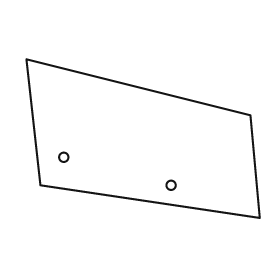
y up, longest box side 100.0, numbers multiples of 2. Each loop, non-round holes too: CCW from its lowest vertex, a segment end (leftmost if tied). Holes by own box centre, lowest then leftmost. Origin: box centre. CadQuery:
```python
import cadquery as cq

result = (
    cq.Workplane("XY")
    .moveTo(50.0, -34.0)
    .lineTo(46.0, 10.0)
    .lineTo(-50.0, 34.0)
    .lineTo(-44.0, -20.0)
    .close()
    .moveTo(12.0, -20.0)
    .circle(2.0)
    .moveTo(-34.0, -8.0)
    .circle(2.0)
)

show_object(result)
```